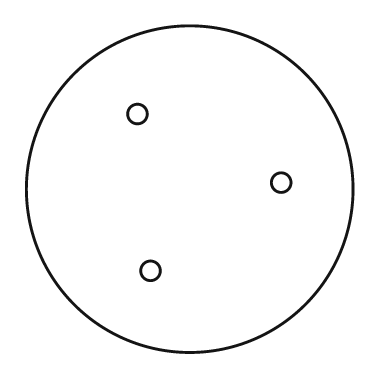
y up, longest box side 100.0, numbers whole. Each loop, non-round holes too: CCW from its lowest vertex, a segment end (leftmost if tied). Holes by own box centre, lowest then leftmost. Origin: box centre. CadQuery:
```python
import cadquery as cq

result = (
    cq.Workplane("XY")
    .moveTo(0.0, 0.0)
    .circle(50.0)
    .moveTo(-12.0, -25.0)
    .circle(3.0)
    .moveTo(28.0, 2.0)
    .circle(3.0)
    .moveTo(-16.0, 23.0)
    .circle(3.0)
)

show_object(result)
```